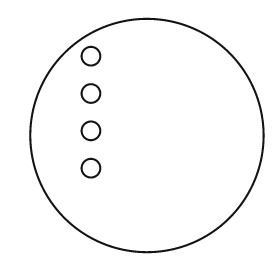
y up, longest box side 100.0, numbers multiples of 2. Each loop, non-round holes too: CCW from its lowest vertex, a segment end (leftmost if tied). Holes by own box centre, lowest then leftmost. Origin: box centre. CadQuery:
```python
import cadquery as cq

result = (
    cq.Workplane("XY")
    .moveTo(0.0, 0.0)
    .circle(50.0)
    .moveTo(-24.0, -14.0)
    .circle(4.0)
    .moveTo(-24.0, 2.0)
    .circle(4.0)
    .moveTo(-24.0, 18.0)
    .circle(4.0)
    .moveTo(-24.0, 34.0)
    .circle(4.0)
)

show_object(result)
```